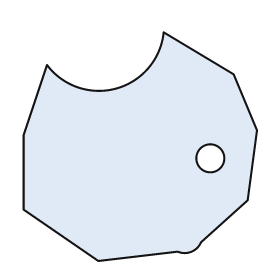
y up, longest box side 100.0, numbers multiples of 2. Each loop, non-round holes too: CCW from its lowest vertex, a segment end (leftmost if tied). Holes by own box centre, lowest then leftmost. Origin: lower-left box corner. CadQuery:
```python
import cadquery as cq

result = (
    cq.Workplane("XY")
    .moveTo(32.0, 0.0)
    .lineTo(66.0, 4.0)
    .threePointArc((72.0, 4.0), (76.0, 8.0))
    .lineTo(96.0, 26.0)
    .lineTo(100.0, 56.0)
    .lineTo(90.0, 80.0)
    .lineTo(60.0, 98.0)
    .threePointArc((40.0, 74.0), (10.0, 84.0))
    .lineTo(0.0, 54.0)
    .lineTo(0.0, 22.0)
    .close()
    .moveTo(80.0, 44.0)
    .circle(6.0)
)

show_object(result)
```